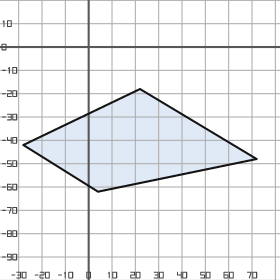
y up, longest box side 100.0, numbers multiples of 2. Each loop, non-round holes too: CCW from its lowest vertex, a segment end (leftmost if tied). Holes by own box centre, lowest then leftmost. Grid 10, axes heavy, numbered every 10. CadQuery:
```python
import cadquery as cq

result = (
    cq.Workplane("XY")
    .moveTo(4.0, -62.0)
    .lineTo(72.0, -48.0)
    .lineTo(22.0, -18.0)
    .lineTo(-28.0, -42.0)
    .close()
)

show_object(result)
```